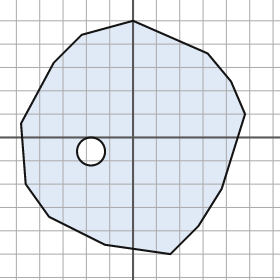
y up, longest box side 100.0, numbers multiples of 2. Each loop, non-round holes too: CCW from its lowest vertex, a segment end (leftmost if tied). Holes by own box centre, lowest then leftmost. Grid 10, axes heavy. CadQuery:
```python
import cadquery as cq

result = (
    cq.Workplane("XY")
    .moveTo(16.0, -50.0)
    .lineTo(28.0, -38.0)
    .lineTo(38.0, -22.0)
    .lineTo(48.0, 10.0)
    .lineTo(42.0, 24.0)
    .lineTo(32.0, 36.0)
    .lineTo(0.0, 50.0)
    .lineTo(-22.0, 44.0)
    .lineTo(-34.0, 32.0)
    .lineTo(-48.0, 6.0)
    .lineTo(-46.0, -20.0)
    .lineTo(-36.0, -34.0)
    .lineTo(-12.0, -46.0)
    .close()
    .moveTo(-18.0, -6.0)
    .circle(6.0)
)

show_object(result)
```